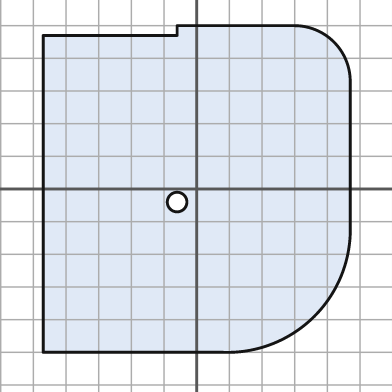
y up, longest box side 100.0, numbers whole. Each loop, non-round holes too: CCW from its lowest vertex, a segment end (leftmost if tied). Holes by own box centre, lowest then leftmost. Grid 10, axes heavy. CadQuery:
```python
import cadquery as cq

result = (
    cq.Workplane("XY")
    .moveTo(-47.0, -50.0)
    .lineTo(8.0, -50.0)
    .threePointArc((36.0, -39.0), (47.0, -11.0))
    .lineTo(47.0, 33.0)
    .threePointArc((42.0, 45.0), (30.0, 50.0))
    .lineTo(-6.0, 50.0)
    .lineTo(-6.0, 47.0)
    .lineTo(-47.0, 47.0)
    .close()
    .moveTo(-6.0, -4.0)
    .circle(3.0)
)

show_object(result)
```